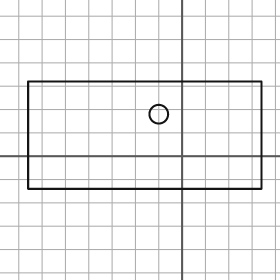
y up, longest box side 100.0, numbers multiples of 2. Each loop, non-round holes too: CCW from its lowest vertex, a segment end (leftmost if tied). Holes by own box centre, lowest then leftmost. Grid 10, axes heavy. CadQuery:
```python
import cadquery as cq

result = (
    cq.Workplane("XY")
    .moveTo(-66.0, -14.0)
    .lineTo(34.0, -14.0)
    .lineTo(34.0, 32.0)
    .lineTo(-66.0, 32.0)
    .close()
    .moveTo(-10.0, 18.0)
    .circle(4.0)
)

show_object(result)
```